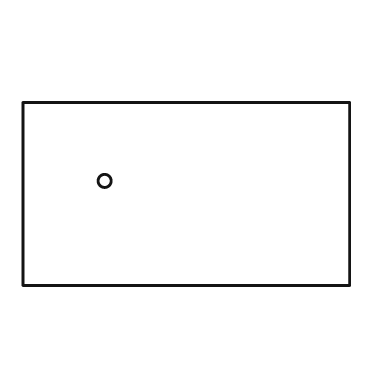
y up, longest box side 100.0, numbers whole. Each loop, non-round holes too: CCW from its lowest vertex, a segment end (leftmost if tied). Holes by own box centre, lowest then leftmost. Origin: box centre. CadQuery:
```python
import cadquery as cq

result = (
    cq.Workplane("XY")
    .moveTo(-50.0, -28.0)
    .lineTo(50.0, -28.0)
    .lineTo(50.0, 28.0)
    .lineTo(-50.0, 28.0)
    .close()
    .moveTo(-25.0, 4.0)
    .circle(2.0)
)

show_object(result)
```